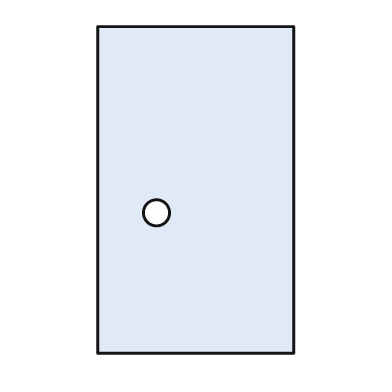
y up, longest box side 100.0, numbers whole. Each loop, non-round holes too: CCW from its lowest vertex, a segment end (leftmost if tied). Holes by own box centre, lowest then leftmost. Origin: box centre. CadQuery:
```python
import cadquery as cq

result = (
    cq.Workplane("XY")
    .moveTo(-30.0, -50.0)
    .lineTo(30.0, -50.0)
    .lineTo(30.0, 50.0)
    .lineTo(-30.0, 50.0)
    .close()
    .moveTo(-12.0, -7.0)
    .circle(4.0)
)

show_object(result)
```